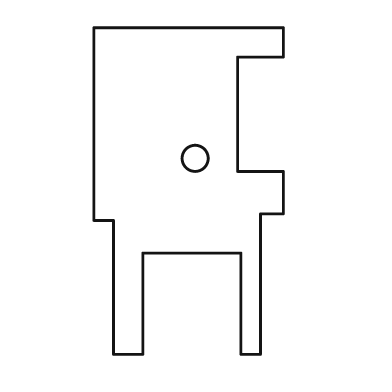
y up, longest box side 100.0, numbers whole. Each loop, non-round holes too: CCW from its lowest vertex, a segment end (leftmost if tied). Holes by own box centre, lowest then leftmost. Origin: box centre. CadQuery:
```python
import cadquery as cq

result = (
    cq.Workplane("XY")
    .moveTo(-23.0, -50.0)
    .lineTo(-14.0, -50.0)
    .lineTo(-14.0, -19.0)
    .lineTo(16.0, -19.0)
    .lineTo(16.0, -50.0)
    .lineTo(22.0, -50.0)
    .lineTo(22.0, -7.0)
    .lineTo(29.0, -7.0)
    .lineTo(29.0, 6.0)
    .lineTo(15.0, 6.0)
    .lineTo(15.0, 41.0)
    .lineTo(29.0, 41.0)
    .lineTo(29.0, 50.0)
    .lineTo(-29.0, 50.0)
    .lineTo(-29.0, -9.0)
    .lineTo(-23.0, -9.0)
    .close()
    .moveTo(2.0, 10.0)
    .circle(4.0)
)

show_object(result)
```